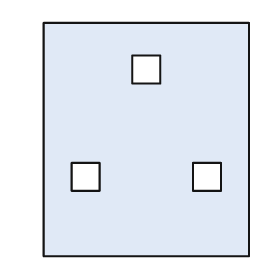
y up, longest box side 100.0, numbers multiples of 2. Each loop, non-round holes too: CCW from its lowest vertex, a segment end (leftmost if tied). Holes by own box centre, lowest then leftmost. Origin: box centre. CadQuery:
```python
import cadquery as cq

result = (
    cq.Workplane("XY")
    .moveTo(-44.0, -50.0)
    .lineTo(44.0, -50.0)
    .lineTo(44.0, 50.0)
    .lineTo(-44.0, 50.0)
    .close()
    .moveTo(-32.0, -22.0)
    .lineTo(-20.0, -22.0)
    .lineTo(-20.0, -10.0)
    .lineTo(-32.0, -10.0)
    .close()
    .moveTo(20.0, -22.0)
    .lineTo(32.0, -22.0)
    .lineTo(32.0, -10.0)
    .lineTo(20.0, -10.0)
    .close()
    .moveTo(-6.0, 24.0)
    .lineTo(6.0, 24.0)
    .lineTo(6.0, 36.0)
    .lineTo(-6.0, 36.0)
    .close()
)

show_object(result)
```